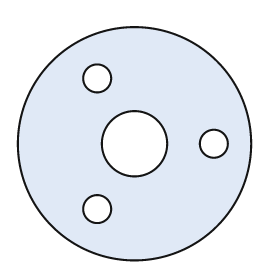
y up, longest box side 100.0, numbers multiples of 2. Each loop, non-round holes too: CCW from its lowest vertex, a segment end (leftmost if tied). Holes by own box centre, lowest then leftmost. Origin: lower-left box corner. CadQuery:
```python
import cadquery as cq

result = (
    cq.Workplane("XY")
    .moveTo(50.0, 50.0)
    .circle(50.0)
    .moveTo(34.0, 22.0)
    .circle(6.0)
    .moveTo(50.0, 50.0)
    .circle(14.0)
    .moveTo(84.0, 50.0)
    .circle(6.0)
    .moveTo(34.0, 78.0)
    .circle(6.0)
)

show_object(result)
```